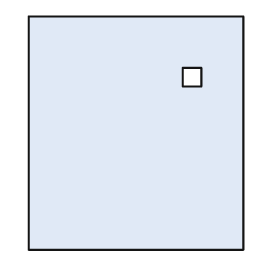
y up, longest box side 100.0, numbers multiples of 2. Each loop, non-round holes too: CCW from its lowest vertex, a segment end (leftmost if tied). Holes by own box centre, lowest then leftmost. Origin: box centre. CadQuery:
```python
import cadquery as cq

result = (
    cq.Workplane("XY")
    .moveTo(-46.0, -50.0)
    .lineTo(46.0, -50.0)
    .lineTo(46.0, 50.0)
    .lineTo(-46.0, 50.0)
    .close()
    .moveTo(20.0, 20.0)
    .lineTo(28.0, 20.0)
    .lineTo(28.0, 28.0)
    .lineTo(20.0, 28.0)
    .close()
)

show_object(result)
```